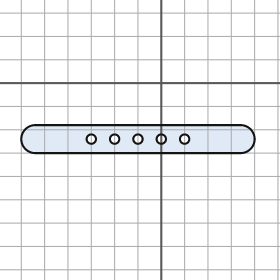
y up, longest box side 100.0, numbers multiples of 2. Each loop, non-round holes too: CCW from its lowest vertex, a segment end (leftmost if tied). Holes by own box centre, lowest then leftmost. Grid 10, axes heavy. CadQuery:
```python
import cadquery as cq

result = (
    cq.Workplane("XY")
    .moveTo(-54.0, -30.0)
    .lineTo(34.0, -30.0)
    .threePointArc((40.0, -24.0), (34.0, -18.0))
    .lineTo(-54.0, -18.0)
    .threePointArc((-60.0, -24.0), (-54.0, -30.0))
    .close()
    .moveTo(-30.0, -24.0)
    .circle(2.0)
    .moveTo(-20.0, -24.0)
    .circle(2.0)
    .moveTo(-10.0, -24.0)
    .circle(2.0)
    .moveTo(0.0, -24.0)
    .circle(2.0)
    .moveTo(10.0, -24.0)
    .circle(2.0)
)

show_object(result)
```